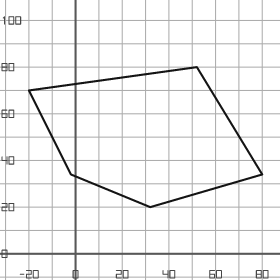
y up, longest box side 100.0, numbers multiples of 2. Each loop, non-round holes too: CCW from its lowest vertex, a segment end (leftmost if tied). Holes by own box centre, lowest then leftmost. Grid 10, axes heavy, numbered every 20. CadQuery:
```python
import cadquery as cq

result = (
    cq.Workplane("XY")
    .moveTo(32.0, 20.0)
    .lineTo(80.0, 34.0)
    .lineTo(52.0, 80.0)
    .lineTo(-20.0, 70.0)
    .lineTo(-2.0, 34.0)
    .close()
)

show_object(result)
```